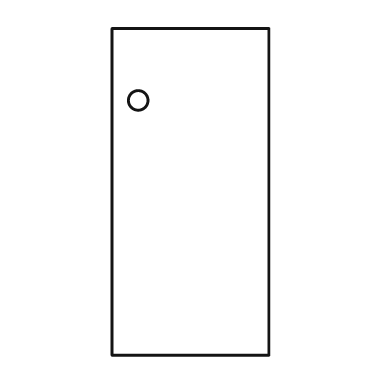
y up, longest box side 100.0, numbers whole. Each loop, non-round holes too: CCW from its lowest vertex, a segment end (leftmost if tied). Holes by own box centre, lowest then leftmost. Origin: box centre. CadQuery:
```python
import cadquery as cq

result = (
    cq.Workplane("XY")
    .moveTo(-24.0, -50.0)
    .lineTo(24.0, -50.0)
    .lineTo(24.0, 50.0)
    .lineTo(-24.0, 50.0)
    .close()
    .moveTo(-16.0, 28.0)
    .circle(3.0)
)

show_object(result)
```